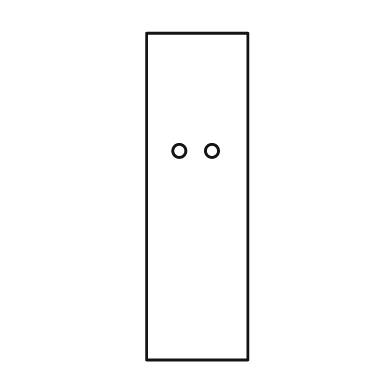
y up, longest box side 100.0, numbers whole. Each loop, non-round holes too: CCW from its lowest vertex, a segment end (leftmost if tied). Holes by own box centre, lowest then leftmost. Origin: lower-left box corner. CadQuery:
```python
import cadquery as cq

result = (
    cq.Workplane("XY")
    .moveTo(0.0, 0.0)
    .lineTo(31.0, 0.0)
    .lineTo(31.0, 100.0)
    .lineTo(0.0, 100.0)
    .close()
    .moveTo(10.0, 64.0)
    .circle(2.0)
    .moveTo(20.0, 64.0)
    .circle(2.0)
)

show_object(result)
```